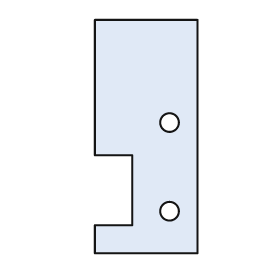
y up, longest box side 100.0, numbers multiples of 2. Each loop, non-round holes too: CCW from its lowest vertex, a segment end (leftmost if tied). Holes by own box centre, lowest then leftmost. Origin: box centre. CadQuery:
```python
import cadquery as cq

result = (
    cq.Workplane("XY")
    .moveTo(-22.0, -50.0)
    .lineTo(22.0, -50.0)
    .lineTo(22.0, 50.0)
    .lineTo(-22.0, 50.0)
    .lineTo(-22.0, -8.0)
    .lineTo(-6.0, -8.0)
    .lineTo(-6.0, -38.0)
    .lineTo(-22.0, -38.0)
    .close()
    .moveTo(10.0, -32.0)
    .circle(4.0)
    .moveTo(10.0, 6.0)
    .circle(4.0)
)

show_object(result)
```